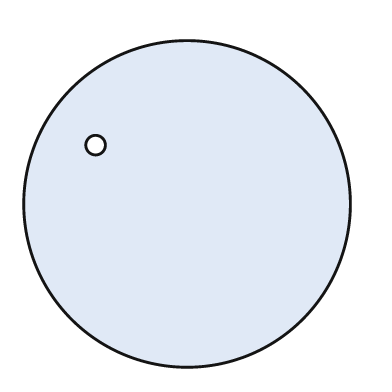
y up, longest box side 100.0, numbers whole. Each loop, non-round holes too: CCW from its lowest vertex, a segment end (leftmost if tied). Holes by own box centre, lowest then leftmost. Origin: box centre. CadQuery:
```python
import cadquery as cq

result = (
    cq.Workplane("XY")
    .moveTo(0.0, 0.0)
    .circle(50.0)
    .moveTo(-28.0, 18.0)
    .circle(3.0)
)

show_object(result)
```